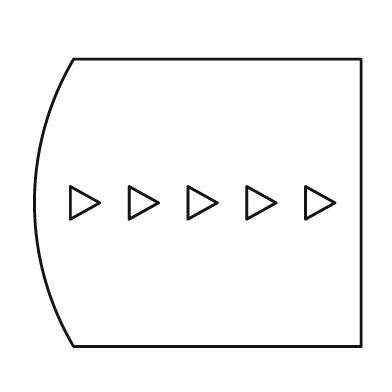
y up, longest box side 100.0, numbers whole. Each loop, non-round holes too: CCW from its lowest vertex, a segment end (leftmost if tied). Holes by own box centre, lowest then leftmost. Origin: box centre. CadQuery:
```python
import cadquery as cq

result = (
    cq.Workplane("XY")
    .moveTo(-38.0, -44.0)
    .lineTo(50.0, -44.0)
    .lineTo(50.0, 44.0)
    .lineTo(-38.0, 44.0)
    .threePointArc((-50.0, 0.0), (-38.0, -44.0))
    .close()
    .moveTo(-39.0, -5.0)
    .lineTo(-30.0, 0.0)
    .lineTo(-39.0, 5.0)
    .close()
    .moveTo(-21.0, -5.0)
    .lineTo(-12.0, 0.0)
    .lineTo(-21.0, 5.0)
    .close()
    .moveTo(-3.0, -5.0)
    .lineTo(6.0, 0.0)
    .lineTo(-3.0, 5.0)
    .close()
    .moveTo(15.0, -5.0)
    .lineTo(24.0, 0.0)
    .lineTo(15.0, 5.0)
    .close()
    .moveTo(33.0, -5.0)
    .lineTo(42.0, 0.0)
    .lineTo(33.0, 5.0)
    .close()
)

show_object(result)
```